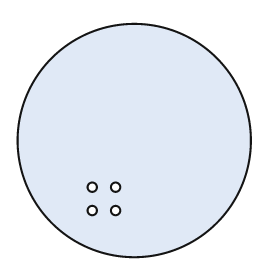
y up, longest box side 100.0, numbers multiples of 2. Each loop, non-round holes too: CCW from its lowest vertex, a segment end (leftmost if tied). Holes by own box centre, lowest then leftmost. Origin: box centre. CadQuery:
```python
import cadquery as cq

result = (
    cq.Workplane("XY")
    .moveTo(0.0, 0.0)
    .circle(50.0)
    .moveTo(-18.0, -30.0)
    .circle(2.0)
    .moveTo(-8.0, -30.0)
    .circle(2.0)
    .moveTo(-18.0, -20.0)
    .circle(2.0)
    .moveTo(-8.0, -20.0)
    .circle(2.0)
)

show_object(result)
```